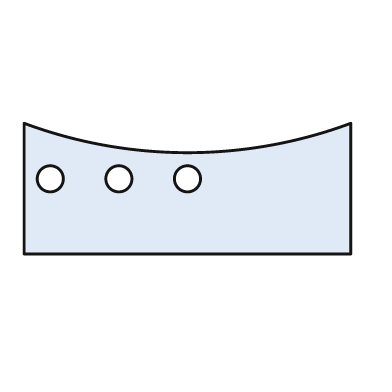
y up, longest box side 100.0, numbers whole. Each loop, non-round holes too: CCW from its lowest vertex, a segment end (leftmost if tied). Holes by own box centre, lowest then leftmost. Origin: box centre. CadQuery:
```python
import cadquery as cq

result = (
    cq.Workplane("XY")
    .moveTo(-50.0, -20.0)
    .lineTo(50.0, -20.0)
    .lineTo(50.0, 20.0)
    .threePointArc((0.0, 11.0), (-50.0, 20.0))
    .close()
    .moveTo(-42.0, 3.0)
    .circle(4.0)
    .moveTo(-21.0, 3.0)
    .circle(4.0)
    .moveTo(0.0, 3.0)
    .circle(4.0)
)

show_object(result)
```